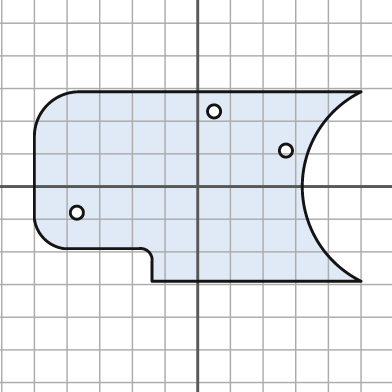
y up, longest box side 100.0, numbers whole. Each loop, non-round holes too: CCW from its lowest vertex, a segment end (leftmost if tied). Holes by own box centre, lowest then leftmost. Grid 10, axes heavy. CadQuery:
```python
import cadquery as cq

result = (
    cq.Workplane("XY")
    .moveTo(-14.0, -29.0)
    .lineTo(50.0, -29.0)
    .threePointArc((32.0, 0.0), (50.0, 29.0))
    .lineTo(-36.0, 29.0)
    .threePointArc((-46.0, 25.0), (-50.0, 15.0))
    .lineTo(-50.0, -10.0)
    .threePointArc((-47.0, -16.0), (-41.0, -19.0))
    .lineTo(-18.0, -19.0)
    .threePointArc((-15.0, -20.0), (-14.0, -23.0))
    .close()
    .moveTo(-37.0, -8.0)
    .circle(2.0)
    .moveTo(27.0, 11.0)
    .circle(2.0)
    .moveTo(5.0, 23.0)
    .circle(2.0)
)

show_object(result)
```